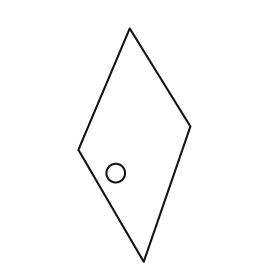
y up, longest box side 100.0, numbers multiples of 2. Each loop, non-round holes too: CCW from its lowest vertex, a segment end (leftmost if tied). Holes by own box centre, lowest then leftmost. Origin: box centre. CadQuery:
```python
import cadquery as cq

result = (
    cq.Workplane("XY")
    .moveTo(4.0, -50.0)
    .lineTo(24.0, 8.0)
    .lineTo(-2.0, 50.0)
    .lineTo(-24.0, -2.0)
    .close()
    .moveTo(-8.0, -12.0)
    .circle(4.0)
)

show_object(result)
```